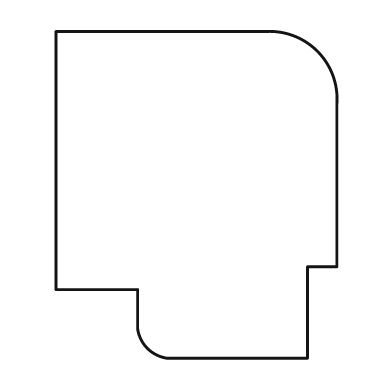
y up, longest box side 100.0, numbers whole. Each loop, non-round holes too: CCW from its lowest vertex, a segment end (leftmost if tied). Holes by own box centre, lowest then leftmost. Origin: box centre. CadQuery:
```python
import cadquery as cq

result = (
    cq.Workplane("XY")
    .moveTo(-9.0, -50.0)
    .lineTo(34.0, -50.0)
    .lineTo(34.0, -22.0)
    .lineTo(43.0, -22.0)
    .lineTo(43.0, 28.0)
    .threePointArc((37.0, 44.0), (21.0, 50.0))
    .lineTo(-43.0, 50.0)
    .lineTo(-43.0, -29.0)
    .lineTo(-18.0, -29.0)
    .lineTo(-18.0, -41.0)
    .threePointArc((-15.0, -47.0), (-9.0, -50.0))
    .close()
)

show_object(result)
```